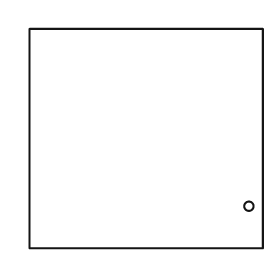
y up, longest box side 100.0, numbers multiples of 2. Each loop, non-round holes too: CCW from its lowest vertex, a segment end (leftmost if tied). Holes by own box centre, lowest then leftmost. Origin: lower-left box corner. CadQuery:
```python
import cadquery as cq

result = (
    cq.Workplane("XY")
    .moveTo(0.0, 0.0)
    .lineTo(100.0, 0.0)
    .lineTo(100.0, 94.0)
    .lineTo(0.0, 94.0)
    .close()
    .moveTo(94.0, 18.0)
    .circle(2.0)
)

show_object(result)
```